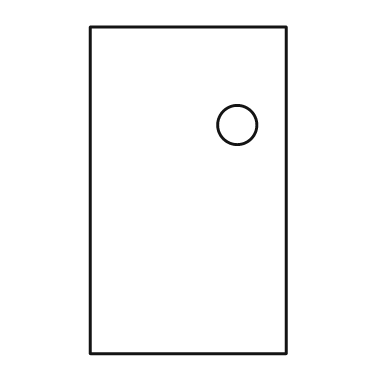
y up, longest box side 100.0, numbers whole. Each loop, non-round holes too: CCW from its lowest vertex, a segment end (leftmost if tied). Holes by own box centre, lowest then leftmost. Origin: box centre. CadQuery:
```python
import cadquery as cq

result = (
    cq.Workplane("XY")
    .moveTo(-30.0, -50.0)
    .lineTo(30.0, -50.0)
    .lineTo(30.0, 50.0)
    .lineTo(-30.0, 50.0)
    .close()
    .moveTo(15.0, 20.0)
    .circle(6.0)
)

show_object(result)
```